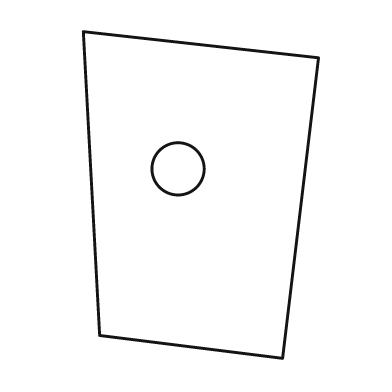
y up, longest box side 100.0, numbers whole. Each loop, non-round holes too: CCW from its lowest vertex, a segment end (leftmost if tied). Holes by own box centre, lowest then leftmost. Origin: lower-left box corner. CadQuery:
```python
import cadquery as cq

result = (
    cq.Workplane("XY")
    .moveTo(61.0, 0.0)
    .lineTo(72.0, 92.0)
    .lineTo(0.0, 100.0)
    .lineTo(5.0, 7.0)
    .close()
    .moveTo(29.0, 58.0)
    .circle(8.0)
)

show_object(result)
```